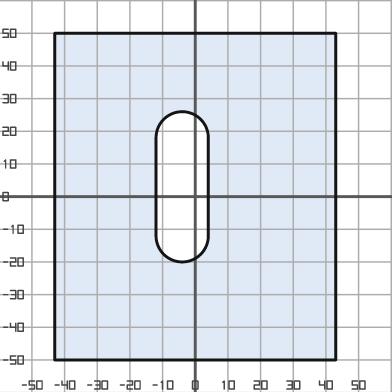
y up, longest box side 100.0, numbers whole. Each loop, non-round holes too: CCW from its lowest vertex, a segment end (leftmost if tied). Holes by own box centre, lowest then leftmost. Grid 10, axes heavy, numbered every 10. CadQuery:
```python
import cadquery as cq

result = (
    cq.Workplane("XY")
    .moveTo(-43.0, -50.0)
    .lineTo(43.0, -50.0)
    .lineTo(43.0, 50.0)
    .lineTo(-43.0, 50.0)
    .close()
    .moveTo(-12.0, -12.0)
    .threePointArc((-4.0, -20.0), (4.0, -12.0))
    .lineTo(4.0, 18.0)
    .threePointArc((-4.0, 26.0), (-12.0, 18.0))
    .close()
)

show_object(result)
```